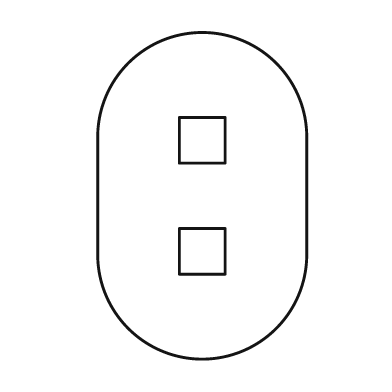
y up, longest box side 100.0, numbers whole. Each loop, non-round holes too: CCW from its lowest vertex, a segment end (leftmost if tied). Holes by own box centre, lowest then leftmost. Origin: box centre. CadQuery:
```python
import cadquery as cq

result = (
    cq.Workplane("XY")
    .moveTo(-32.0, -18.0)
    .threePointArc((0.0, -50.0), (32.0, -18.0))
    .lineTo(32.0, 18.0)
    .threePointArc((0.0, 50.0), (-32.0, 18.0))
    .close()
    .moveTo(-7.0, -24.0)
    .lineTo(7.0, -24.0)
    .lineTo(7.0, -10.0)
    .lineTo(-7.0, -10.0)
    .close()
    .moveTo(-7.0, 10.0)
    .lineTo(7.0, 10.0)
    .lineTo(7.0, 24.0)
    .lineTo(-7.0, 24.0)
    .close()
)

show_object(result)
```